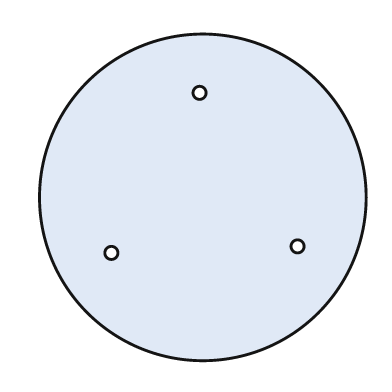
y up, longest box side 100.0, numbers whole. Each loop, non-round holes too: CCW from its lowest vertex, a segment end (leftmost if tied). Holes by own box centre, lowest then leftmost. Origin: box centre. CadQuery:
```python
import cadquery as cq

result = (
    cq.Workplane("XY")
    .moveTo(0.0, 0.0)
    .circle(50.0)
    .moveTo(-28.0, -17.0)
    .circle(2.0)
    .moveTo(29.0, -15.0)
    .circle(2.0)
    .moveTo(-1.0, 32.0)
    .circle(2.0)
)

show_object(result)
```